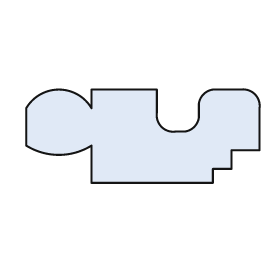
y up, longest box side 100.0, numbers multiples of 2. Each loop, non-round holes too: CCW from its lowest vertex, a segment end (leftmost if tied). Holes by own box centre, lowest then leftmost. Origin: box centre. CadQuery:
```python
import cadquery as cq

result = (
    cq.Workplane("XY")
    .moveTo(-22.0, -20.0)
    .lineTo(30.0, -20.0)
    .lineTo(30.0, -14.0)
    .lineTo(38.0, -14.0)
    .lineTo(38.0, -6.0)
    .lineTo(50.0, -6.0)
    .lineTo(50.0, 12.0)
    .threePointArc((48.0, 18.0), (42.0, 20.0))
    .lineTo(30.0, 20.0)
    .threePointArc((26.0, 18.0), (24.0, 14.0))
    .lineTo(24.0, 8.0)
    .threePointArc((22.0, 4.0), (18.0, 2.0))
    .lineTo(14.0, 2.0)
    .threePointArc((8.0, 4.0), (6.0, 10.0))
    .lineTo(6.0, 20.0)
    .lineTo(-22.0, 20.0)
    .lineTo(-22.0, 12.0)
    .threePointArc((-36.0, 20.0), (-50.0, 12.0))
    .lineTo(-50.0, -4.0)
    .threePointArc((-36.0, -8.0), (-22.0, -4.0))
    .close()
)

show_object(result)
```